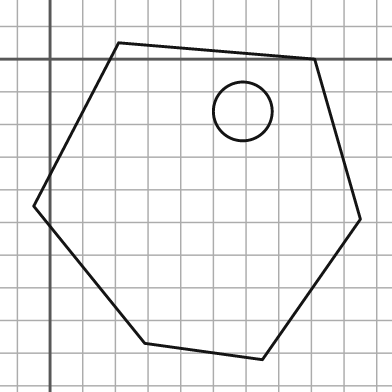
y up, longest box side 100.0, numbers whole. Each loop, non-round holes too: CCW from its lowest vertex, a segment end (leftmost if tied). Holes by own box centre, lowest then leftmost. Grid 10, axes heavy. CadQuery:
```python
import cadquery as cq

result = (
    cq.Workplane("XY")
    .moveTo(65.0, -92.0)
    .lineTo(95.0, -49.0)
    .lineTo(81.0, 0.0)
    .lineTo(21.0, 5.0)
    .lineTo(-5.0, -45.0)
    .lineTo(29.0, -87.0)
    .close()
    .moveTo(59.0, -16.0)
    .circle(9.0)
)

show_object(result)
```